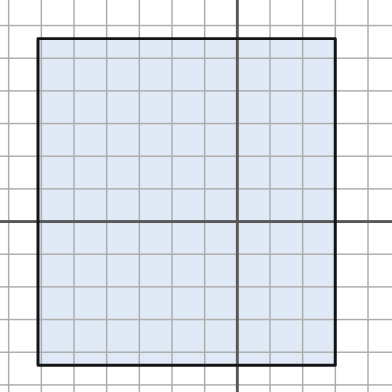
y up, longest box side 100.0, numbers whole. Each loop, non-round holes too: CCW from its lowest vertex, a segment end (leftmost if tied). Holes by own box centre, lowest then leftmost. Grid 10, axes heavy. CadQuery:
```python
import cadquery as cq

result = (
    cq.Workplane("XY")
    .moveTo(-61.0, -44.0)
    .lineTo(30.0, -44.0)
    .lineTo(30.0, 56.0)
    .lineTo(-61.0, 56.0)
    .close()
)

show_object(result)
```